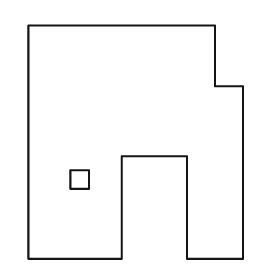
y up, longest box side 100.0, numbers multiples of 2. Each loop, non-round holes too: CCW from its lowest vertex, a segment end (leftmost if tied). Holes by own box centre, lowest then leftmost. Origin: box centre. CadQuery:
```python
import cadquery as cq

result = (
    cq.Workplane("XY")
    .moveTo(-46.0, -50.0)
    .lineTo(-6.0, -50.0)
    .lineTo(-6.0, -6.0)
    .lineTo(22.0, -6.0)
    .lineTo(22.0, -50.0)
    .lineTo(46.0, -50.0)
    .lineTo(46.0, 24.0)
    .lineTo(34.0, 24.0)
    .lineTo(34.0, 50.0)
    .lineTo(-46.0, 50.0)
    .close()
    .moveTo(-28.0, -20.0)
    .lineTo(-20.0, -20.0)
    .lineTo(-20.0, -12.0)
    .lineTo(-28.0, -12.0)
    .close()
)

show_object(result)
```